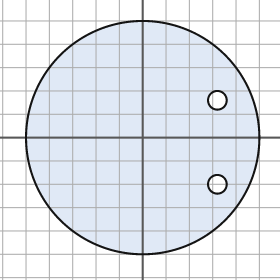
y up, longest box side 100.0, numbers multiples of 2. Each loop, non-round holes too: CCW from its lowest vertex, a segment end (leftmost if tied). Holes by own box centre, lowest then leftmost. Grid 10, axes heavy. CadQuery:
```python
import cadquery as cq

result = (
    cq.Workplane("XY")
    .moveTo(0.0, 0.0)
    .circle(50.0)
    .moveTo(32.0, -20.0)
    .circle(4.0)
    .moveTo(32.0, 16.0)
    .circle(4.0)
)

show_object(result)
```